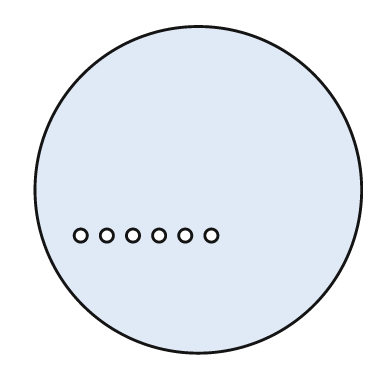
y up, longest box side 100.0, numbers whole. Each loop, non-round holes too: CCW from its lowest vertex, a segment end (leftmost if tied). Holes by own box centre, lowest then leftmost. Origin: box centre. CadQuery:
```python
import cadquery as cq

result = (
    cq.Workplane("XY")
    .moveTo(0.0, 0.0)
    .circle(50.0)
    .moveTo(-36.0, -14.0)
    .circle(2.0)
    .moveTo(-28.0, -14.0)
    .circle(2.0)
    .moveTo(-20.0, -14.0)
    .circle(2.0)
    .moveTo(-12.0, -14.0)
    .circle(2.0)
    .moveTo(-4.0, -14.0)
    .circle(2.0)
    .moveTo(4.0, -14.0)
    .circle(2.0)
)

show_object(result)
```